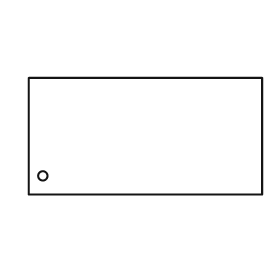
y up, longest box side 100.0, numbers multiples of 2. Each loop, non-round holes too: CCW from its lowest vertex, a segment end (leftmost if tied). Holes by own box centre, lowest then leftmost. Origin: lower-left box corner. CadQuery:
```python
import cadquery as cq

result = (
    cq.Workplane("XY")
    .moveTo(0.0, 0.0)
    .lineTo(100.0, 0.0)
    .lineTo(100.0, 50.0)
    .lineTo(0.0, 50.0)
    .close()
    .moveTo(6.0, 8.0)
    .circle(2.0)
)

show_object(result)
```